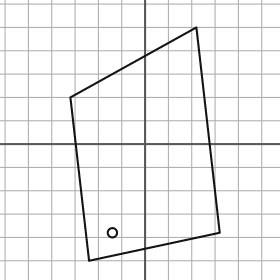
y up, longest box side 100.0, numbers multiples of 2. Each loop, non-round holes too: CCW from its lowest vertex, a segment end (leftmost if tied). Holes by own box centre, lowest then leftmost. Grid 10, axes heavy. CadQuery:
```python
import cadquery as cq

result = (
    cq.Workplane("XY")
    .moveTo(-24.0, -50.0)
    .lineTo(32.0, -38.0)
    .lineTo(22.0, 50.0)
    .lineTo(-32.0, 20.0)
    .close()
    .moveTo(-14.0, -38.0)
    .circle(2.0)
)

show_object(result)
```